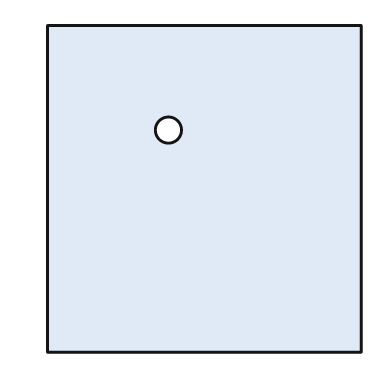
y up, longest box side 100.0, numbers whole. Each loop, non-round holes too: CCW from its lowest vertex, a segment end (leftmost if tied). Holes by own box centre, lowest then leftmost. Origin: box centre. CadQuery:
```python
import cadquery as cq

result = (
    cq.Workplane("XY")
    .moveTo(-48.0, -50.0)
    .lineTo(48.0, -50.0)
    .lineTo(48.0, 50.0)
    .lineTo(-48.0, 50.0)
    .close()
    .moveTo(-11.0, 18.0)
    .circle(4.0)
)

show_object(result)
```